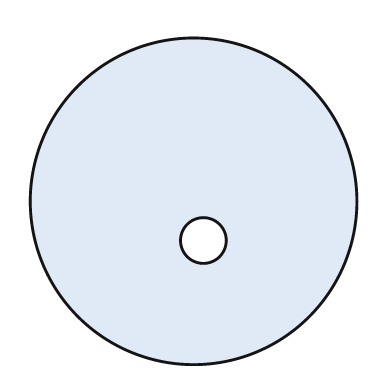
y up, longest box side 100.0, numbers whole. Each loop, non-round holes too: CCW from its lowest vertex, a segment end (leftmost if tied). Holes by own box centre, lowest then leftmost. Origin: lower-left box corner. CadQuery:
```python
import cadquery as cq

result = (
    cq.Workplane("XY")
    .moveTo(50.0, 50.0)
    .circle(50.0)
    .moveTo(53.0, 38.0)
    .circle(7.0)
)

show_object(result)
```